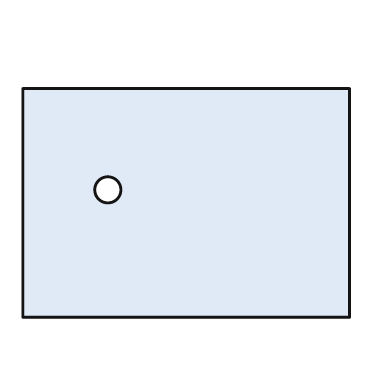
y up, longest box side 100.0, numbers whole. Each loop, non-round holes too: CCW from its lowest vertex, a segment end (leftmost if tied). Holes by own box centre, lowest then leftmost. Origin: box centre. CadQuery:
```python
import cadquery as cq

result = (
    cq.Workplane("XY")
    .moveTo(-50.0, -35.0)
    .lineTo(50.0, -35.0)
    .lineTo(50.0, 35.0)
    .lineTo(-50.0, 35.0)
    .close()
    .moveTo(-24.0, 4.0)
    .circle(4.0)
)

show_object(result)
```